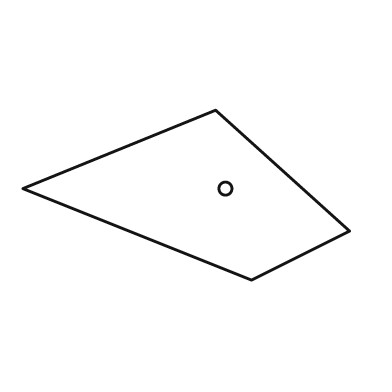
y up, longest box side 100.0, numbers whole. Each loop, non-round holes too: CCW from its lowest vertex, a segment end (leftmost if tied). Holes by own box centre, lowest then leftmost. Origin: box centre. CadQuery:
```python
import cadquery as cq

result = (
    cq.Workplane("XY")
    .moveTo(20.0, -26.0)
    .lineTo(50.0, -11.0)
    .lineTo(9.0, 26.0)
    .lineTo(-50.0, 2.0)
    .close()
    .moveTo(12.0, 2.0)
    .circle(2.0)
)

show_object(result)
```